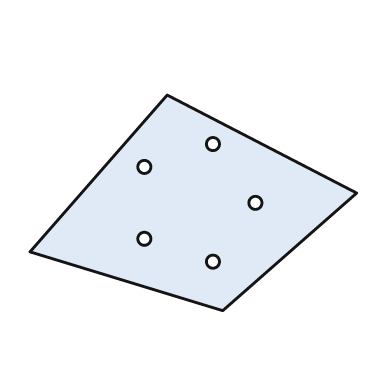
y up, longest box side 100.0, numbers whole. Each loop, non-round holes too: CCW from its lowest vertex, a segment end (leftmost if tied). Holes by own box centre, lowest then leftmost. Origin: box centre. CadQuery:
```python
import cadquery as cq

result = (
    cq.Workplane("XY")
    .moveTo(9.0, -33.0)
    .lineTo(50.0, 3.0)
    .lineTo(-8.0, 33.0)
    .lineTo(-50.0, -15.0)
    .close()
    .moveTo(6.0, -18.0)
    .circle(2.0)
    .moveTo(-15.0, -11.0)
    .circle(2.0)
    .moveTo(19.0, 0.0)
    .circle(2.0)
    .moveTo(-15.0, 11.0)
    .circle(2.0)
    .moveTo(6.0, 18.0)
    .circle(2.0)
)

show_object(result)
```